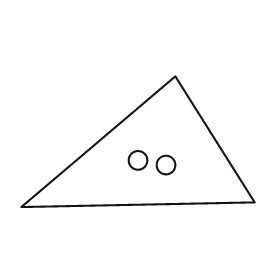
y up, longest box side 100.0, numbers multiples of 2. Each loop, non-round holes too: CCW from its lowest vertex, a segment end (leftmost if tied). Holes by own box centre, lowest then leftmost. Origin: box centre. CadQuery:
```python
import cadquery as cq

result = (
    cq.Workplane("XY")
    .moveTo(-50.0, -28.0)
    .lineTo(50.0, -26.0)
    .lineTo(16.0, 28.0)
    .close()
    .moveTo(12.0, -10.0)
    .circle(4.0)
    .moveTo(0.0, -8.0)
    .circle(4.0)
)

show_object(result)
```